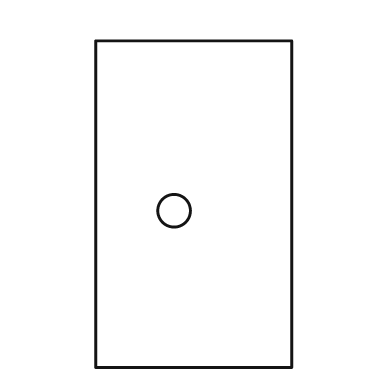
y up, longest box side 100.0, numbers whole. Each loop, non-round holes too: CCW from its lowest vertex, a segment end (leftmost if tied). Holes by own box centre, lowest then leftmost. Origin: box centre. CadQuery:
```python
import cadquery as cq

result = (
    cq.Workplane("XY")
    .moveTo(-30.0, -50.0)
    .lineTo(30.0, -50.0)
    .lineTo(30.0, 50.0)
    .lineTo(-30.0, 50.0)
    .close()
    .moveTo(-6.0, -2.0)
    .circle(5.0)
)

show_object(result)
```